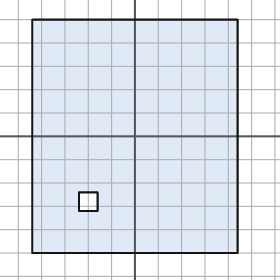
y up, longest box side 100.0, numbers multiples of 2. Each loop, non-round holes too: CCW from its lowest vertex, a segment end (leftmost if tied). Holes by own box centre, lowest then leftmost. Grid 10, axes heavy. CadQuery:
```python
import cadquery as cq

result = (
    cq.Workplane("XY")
    .moveTo(-44.0, -50.0)
    .lineTo(44.0, -50.0)
    .lineTo(44.0, 50.0)
    .lineTo(-44.0, 50.0)
    .close()
    .moveTo(-24.0, -32.0)
    .lineTo(-16.0, -32.0)
    .lineTo(-16.0, -24.0)
    .lineTo(-24.0, -24.0)
    .close()
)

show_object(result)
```